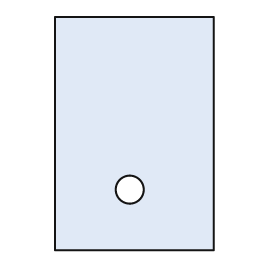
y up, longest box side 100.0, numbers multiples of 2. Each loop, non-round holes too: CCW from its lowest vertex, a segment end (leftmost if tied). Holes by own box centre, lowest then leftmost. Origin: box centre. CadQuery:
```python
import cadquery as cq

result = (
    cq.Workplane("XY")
    .moveTo(-34.0, -50.0)
    .lineTo(34.0, -50.0)
    .lineTo(34.0, 50.0)
    .lineTo(-34.0, 50.0)
    .close()
    .moveTo(-2.0, -24.0)
    .circle(6.0)
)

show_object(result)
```